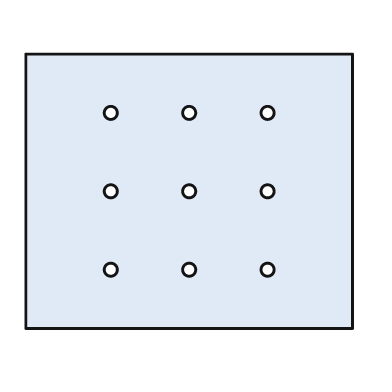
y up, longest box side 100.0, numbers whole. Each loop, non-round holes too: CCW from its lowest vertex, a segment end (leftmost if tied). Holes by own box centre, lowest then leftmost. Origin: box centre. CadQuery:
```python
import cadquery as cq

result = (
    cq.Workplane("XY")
    .moveTo(-50.0, -42.0)
    .lineTo(50.0, -42.0)
    .lineTo(50.0, 42.0)
    .lineTo(-50.0, 42.0)
    .close()
    .moveTo(-24.0, -24.0)
    .circle(2.0)
    .moveTo(0.0, -24.0)
    .circle(2.0)
    .moveTo(24.0, -24.0)
    .circle(2.0)
    .moveTo(-24.0, 0.0)
    .circle(2.0)
    .moveTo(0.0, 0.0)
    .circle(2.0)
    .moveTo(24.0, 0.0)
    .circle(2.0)
    .moveTo(-24.0, 24.0)
    .circle(2.0)
    .moveTo(0.0, 24.0)
    .circle(2.0)
    .moveTo(24.0, 24.0)
    .circle(2.0)
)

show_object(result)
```